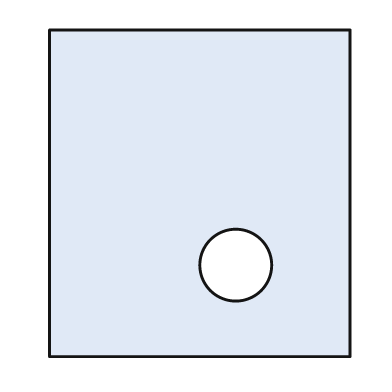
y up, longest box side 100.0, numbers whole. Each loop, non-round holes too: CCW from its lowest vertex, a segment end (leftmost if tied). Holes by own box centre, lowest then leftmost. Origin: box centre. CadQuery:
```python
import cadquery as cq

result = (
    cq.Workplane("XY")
    .moveTo(-46.0, -50.0)
    .lineTo(46.0, -50.0)
    .lineTo(46.0, 50.0)
    .lineTo(-46.0, 50.0)
    .close()
    .moveTo(11.0, -22.0)
    .circle(11.0)
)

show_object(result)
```